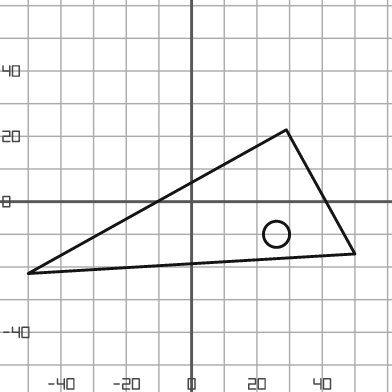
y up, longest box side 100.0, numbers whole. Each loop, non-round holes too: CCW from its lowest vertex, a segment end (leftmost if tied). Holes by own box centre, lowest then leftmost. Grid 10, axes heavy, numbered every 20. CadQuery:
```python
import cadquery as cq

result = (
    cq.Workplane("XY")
    .moveTo(-50.0, -22.0)
    .lineTo(50.0, -16.0)
    .lineTo(29.0, 22.0)
    .close()
    .moveTo(26.0, -10.0)
    .circle(4.0)
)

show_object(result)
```